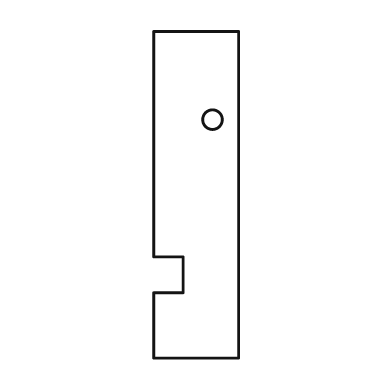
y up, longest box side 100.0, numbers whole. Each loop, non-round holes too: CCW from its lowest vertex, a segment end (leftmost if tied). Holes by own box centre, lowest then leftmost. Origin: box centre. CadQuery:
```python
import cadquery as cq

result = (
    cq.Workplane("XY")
    .moveTo(-13.0, -50.0)
    .lineTo(13.0, -50.0)
    .lineTo(13.0, 50.0)
    .lineTo(-13.0, 50.0)
    .lineTo(-13.0, -19.0)
    .lineTo(-4.0, -19.0)
    .lineTo(-4.0, -30.0)
    .lineTo(-13.0, -30.0)
    .close()
    .moveTo(5.0, 23.0)
    .circle(3.0)
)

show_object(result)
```